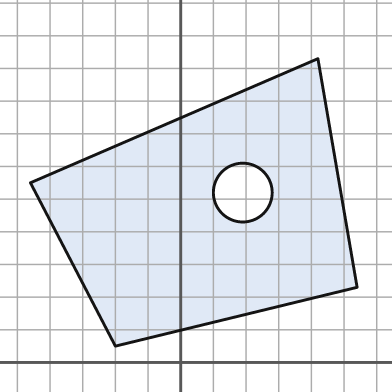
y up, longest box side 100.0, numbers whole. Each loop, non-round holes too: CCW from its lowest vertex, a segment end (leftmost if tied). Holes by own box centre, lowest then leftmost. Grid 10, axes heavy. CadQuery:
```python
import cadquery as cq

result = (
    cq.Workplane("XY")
    .moveTo(-20.0, 5.0)
    .lineTo(54.0, 23.0)
    .lineTo(42.0, 93.0)
    .lineTo(-46.0, 55.0)
    .close()
    .moveTo(19.0, 52.0)
    .circle(9.0)
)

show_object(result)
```